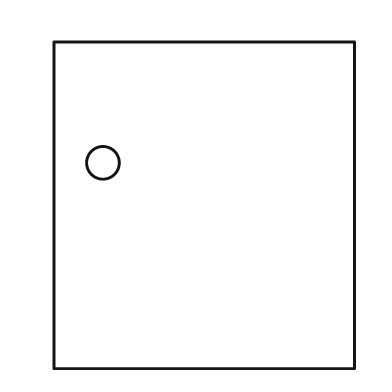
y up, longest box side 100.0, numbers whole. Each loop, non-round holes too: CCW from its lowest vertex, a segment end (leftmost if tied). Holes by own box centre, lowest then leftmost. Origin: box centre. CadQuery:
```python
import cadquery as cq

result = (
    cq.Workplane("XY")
    .moveTo(-46.0, -50.0)
    .lineTo(46.0, -50.0)
    .lineTo(46.0, 50.0)
    .lineTo(-46.0, 50.0)
    .close()
    .moveTo(-31.0, 13.0)
    .circle(5.0)
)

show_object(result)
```